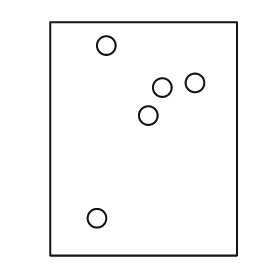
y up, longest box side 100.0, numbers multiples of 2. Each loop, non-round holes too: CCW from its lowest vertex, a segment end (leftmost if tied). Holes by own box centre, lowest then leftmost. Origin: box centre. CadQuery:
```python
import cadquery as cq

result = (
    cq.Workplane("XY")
    .moveTo(-40.0, -50.0)
    .lineTo(40.0, -50.0)
    .lineTo(40.0, 50.0)
    .lineTo(-40.0, 50.0)
    .close()
    .moveTo(-20.0, -34.0)
    .circle(4.0)
    .moveTo(2.0, 10.0)
    .circle(4.0)
    .moveTo(8.0, 22.0)
    .circle(4.0)
    .moveTo(22.0, 24.0)
    .circle(4.0)
    .moveTo(-16.0, 40.0)
    .circle(4.0)
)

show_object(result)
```